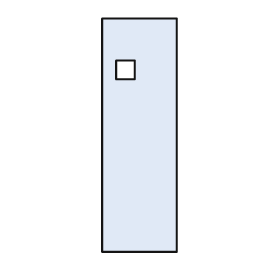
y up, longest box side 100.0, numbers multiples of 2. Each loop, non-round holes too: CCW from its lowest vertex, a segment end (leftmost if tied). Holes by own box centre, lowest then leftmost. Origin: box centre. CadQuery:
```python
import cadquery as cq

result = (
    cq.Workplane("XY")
    .moveTo(-16.0, -50.0)
    .lineTo(16.0, -50.0)
    .lineTo(16.0, 50.0)
    .lineTo(-16.0, 50.0)
    .close()
    .moveTo(-10.0, 24.0)
    .lineTo(-2.0, 24.0)
    .lineTo(-2.0, 32.0)
    .lineTo(-10.0, 32.0)
    .close()
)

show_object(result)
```